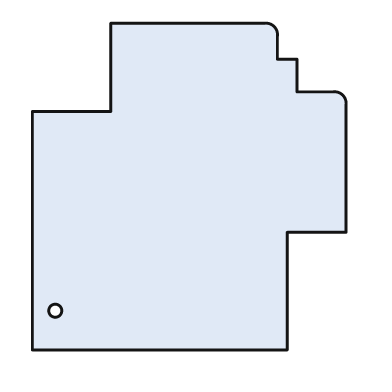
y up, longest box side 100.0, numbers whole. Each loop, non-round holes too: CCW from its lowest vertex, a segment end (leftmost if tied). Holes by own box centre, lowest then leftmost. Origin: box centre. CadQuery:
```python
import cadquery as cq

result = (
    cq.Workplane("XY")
    .moveTo(-48.0, -50.0)
    .lineTo(30.0, -50.0)
    .lineTo(30.0, -14.0)
    .lineTo(48.0, -14.0)
    .lineTo(48.0, 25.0)
    .threePointArc((47.0, 28.0), (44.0, 29.0))
    .lineTo(33.0, 29.0)
    .lineTo(33.0, 39.0)
    .lineTo(27.0, 39.0)
    .lineTo(27.0, 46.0)
    .threePointArc((26.0, 49.0), (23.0, 50.0))
    .lineTo(-24.0, 50.0)
    .lineTo(-24.0, 23.0)
    .lineTo(-48.0, 23.0)
    .close()
    .moveTo(-41.0, -38.0)
    .circle(2.0)
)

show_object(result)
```